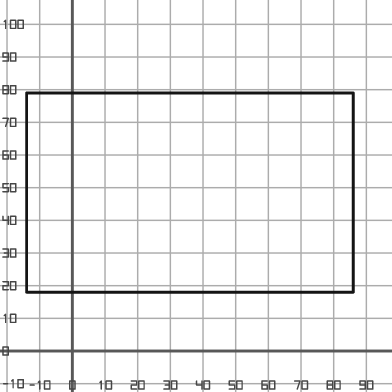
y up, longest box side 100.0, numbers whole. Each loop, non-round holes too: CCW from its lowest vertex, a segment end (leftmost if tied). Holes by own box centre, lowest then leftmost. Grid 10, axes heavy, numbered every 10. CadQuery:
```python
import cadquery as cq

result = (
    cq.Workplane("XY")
    .moveTo(-14.0, 18.0)
    .lineTo(86.0, 18.0)
    .lineTo(86.0, 79.0)
    .lineTo(-14.0, 79.0)
    .close()
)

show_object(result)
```